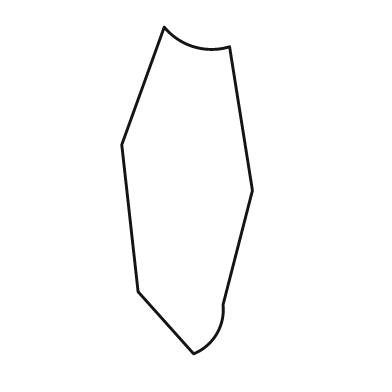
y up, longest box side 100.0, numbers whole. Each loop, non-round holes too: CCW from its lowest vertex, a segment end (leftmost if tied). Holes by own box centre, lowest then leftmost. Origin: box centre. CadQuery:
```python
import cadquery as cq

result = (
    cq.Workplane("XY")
    .moveTo(2.0, -50.0)
    .threePointArc((9.0, -44.0), (11.0, -35.0))
    .lineTo(20.0, 0.0)
    .lineTo(13.0, 44.0)
    .threePointArc((2.0, 44.0), (-7.0, 50.0))
    .lineTo(-20.0, 14.0)
    .lineTo(-15.0, -31.0)
    .close()
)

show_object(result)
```